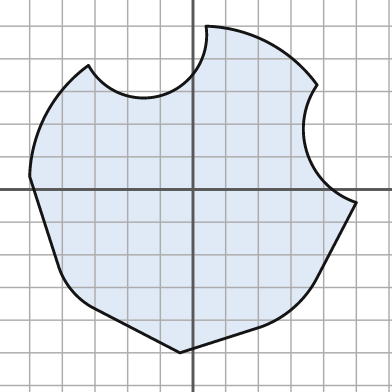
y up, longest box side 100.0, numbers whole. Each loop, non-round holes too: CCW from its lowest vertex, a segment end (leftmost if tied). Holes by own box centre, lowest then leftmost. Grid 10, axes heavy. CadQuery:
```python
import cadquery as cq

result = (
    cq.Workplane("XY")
    .moveTo(-4.0, -50.0)
    .lineTo(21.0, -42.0)
    .threePointArc((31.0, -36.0), (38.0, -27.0))
    .lineTo(50.0, -4.0)
    .threePointArc((35.0, 11.0), (38.0, 32.0))
    .threePointArc((23.0, 45.0), (4.0, 50.0))
    .threePointArc((-9.0, 29.0), (-32.0, 38.0))
    .threePointArc((-45.0, 23.0), (-50.0, 4.0))
    .lineTo(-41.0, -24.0)
    .threePointArc((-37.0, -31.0), (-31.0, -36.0))
    .close()
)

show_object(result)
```